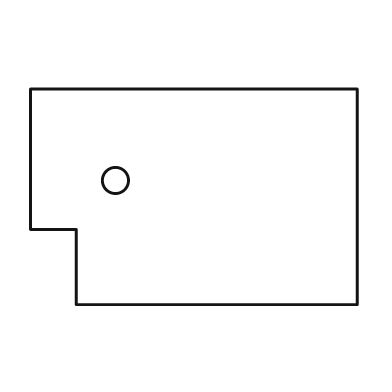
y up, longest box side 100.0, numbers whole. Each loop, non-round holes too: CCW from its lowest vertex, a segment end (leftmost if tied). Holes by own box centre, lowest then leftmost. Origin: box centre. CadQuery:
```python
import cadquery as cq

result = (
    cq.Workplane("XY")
    .moveTo(-36.0, -33.0)
    .lineTo(50.0, -33.0)
    .lineTo(50.0, 33.0)
    .lineTo(-50.0, 33.0)
    .lineTo(-50.0, -10.0)
    .lineTo(-36.0, -10.0)
    .close()
    .moveTo(-24.0, 5.0)
    .circle(4.0)
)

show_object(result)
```